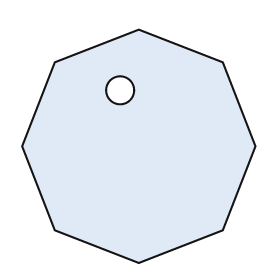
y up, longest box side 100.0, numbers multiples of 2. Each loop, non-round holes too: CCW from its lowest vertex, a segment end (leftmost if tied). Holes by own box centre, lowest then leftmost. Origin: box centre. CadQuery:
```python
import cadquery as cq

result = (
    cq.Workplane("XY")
    .moveTo(0.0, -50.0)
    .lineTo(36.0, -36.0)
    .lineTo(50.0, 0.0)
    .lineTo(36.0, 36.0)
    .lineTo(0.0, 50.0)
    .lineTo(-36.0, 36.0)
    .lineTo(-50.0, 0.0)
    .lineTo(-36.0, -36.0)
    .close()
    .moveTo(-8.0, 24.0)
    .circle(6.0)
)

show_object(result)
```